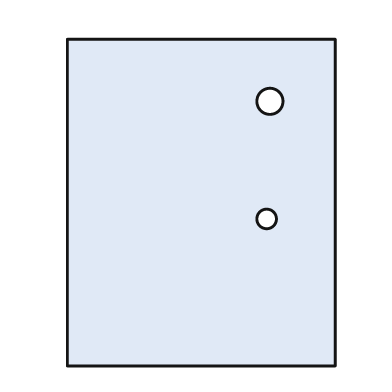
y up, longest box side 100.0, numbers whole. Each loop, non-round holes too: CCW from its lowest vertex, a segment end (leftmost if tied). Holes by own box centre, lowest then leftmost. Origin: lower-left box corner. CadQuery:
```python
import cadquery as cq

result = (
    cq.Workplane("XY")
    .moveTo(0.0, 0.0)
    .lineTo(82.0, 0.0)
    .lineTo(82.0, 100.0)
    .lineTo(0.0, 100.0)
    .close()
    .moveTo(61.0, 45.0)
    .circle(3.0)
    .moveTo(62.0, 81.0)
    .circle(4.0)
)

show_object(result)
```